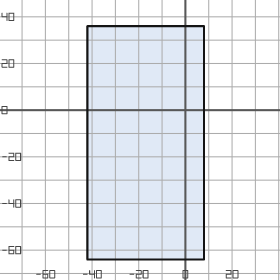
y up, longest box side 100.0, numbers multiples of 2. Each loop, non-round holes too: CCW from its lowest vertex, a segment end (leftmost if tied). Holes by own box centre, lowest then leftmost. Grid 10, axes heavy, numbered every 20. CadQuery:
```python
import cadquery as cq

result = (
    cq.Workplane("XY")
    .moveTo(-42.0, -64.0)
    .lineTo(8.0, -64.0)
    .lineTo(8.0, 36.0)
    .lineTo(-42.0, 36.0)
    .close()
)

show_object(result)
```